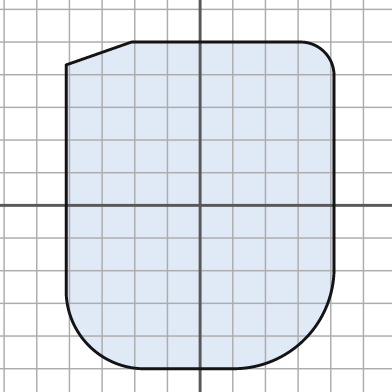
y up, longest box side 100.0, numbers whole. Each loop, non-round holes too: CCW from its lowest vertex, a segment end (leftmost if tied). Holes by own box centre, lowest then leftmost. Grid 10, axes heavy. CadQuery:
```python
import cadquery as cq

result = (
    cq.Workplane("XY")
    .moveTo(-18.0, -50.0)
    .lineTo(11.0, -50.0)
    .threePointArc((32.0, -41.0), (41.0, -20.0))
    .lineTo(41.0, 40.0)
    .threePointArc((38.0, 47.0), (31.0, 50.0))
    .lineTo(-21.0, 50.0)
    .lineTo(-41.0, 43.0)
    .lineTo(-41.0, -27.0)
    .threePointArc((-34.0, -43.0), (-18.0, -50.0))
    .close()
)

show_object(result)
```